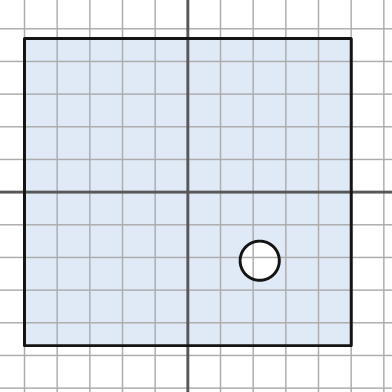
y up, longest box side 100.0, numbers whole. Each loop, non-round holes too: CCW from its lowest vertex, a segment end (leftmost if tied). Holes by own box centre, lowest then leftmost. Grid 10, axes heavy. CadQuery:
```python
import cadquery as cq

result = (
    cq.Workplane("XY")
    .moveTo(-50.0, -47.0)
    .lineTo(50.0, -47.0)
    .lineTo(50.0, 47.0)
    .lineTo(-50.0, 47.0)
    .close()
    .moveTo(22.0, -21.0)
    .circle(6.0)
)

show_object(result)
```